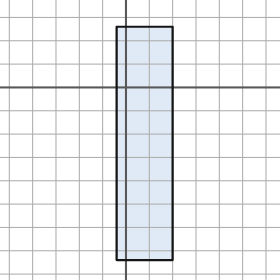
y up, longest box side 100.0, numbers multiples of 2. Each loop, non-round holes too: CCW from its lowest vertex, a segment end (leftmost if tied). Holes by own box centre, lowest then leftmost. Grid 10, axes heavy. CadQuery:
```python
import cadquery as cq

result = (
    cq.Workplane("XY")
    .moveTo(-4.0, -74.0)
    .lineTo(20.0, -74.0)
    .lineTo(20.0, 26.0)
    .lineTo(-4.0, 26.0)
    .close()
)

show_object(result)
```